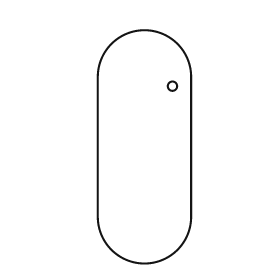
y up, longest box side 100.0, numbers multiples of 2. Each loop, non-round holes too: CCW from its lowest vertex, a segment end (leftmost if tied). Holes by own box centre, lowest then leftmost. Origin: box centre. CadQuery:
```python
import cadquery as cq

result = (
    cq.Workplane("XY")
    .moveTo(-20.0, -30.0)
    .threePointArc((0.0, -50.0), (20.0, -30.0))
    .lineTo(20.0, 30.0)
    .threePointArc((0.0, 50.0), (-20.0, 30.0))
    .close()
    .moveTo(12.0, 26.0)
    .circle(2.0)
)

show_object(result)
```